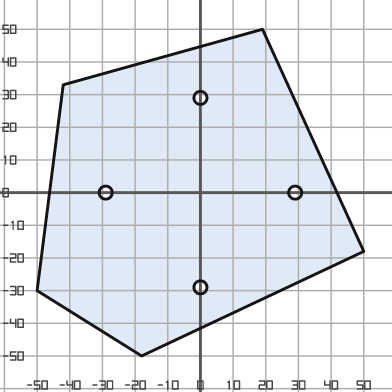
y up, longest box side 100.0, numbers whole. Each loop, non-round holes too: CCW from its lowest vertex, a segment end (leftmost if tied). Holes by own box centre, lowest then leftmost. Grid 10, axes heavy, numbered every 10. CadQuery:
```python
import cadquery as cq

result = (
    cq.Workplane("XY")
    .moveTo(-18.0, -50.0)
    .lineTo(50.0, -18.0)
    .lineTo(19.0, 50.0)
    .lineTo(-42.0, 33.0)
    .lineTo(-50.0, -30.0)
    .close()
    .moveTo(0.0, -29.0)
    .circle(2.0)
    .moveTo(-29.0, 0.0)
    .circle(2.0)
    .moveTo(29.0, 0.0)
    .circle(2.0)
    .moveTo(0.0, 29.0)
    .circle(2.0)
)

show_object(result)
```